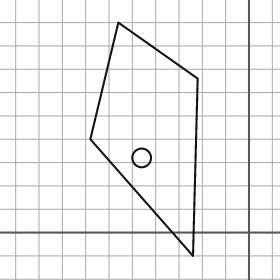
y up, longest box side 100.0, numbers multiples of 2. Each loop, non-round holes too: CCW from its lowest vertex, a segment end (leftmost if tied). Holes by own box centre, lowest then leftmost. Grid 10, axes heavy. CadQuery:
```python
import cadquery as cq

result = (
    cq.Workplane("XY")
    .moveTo(-24.0, -10.0)
    .lineTo(-22.0, 66.0)
    .lineTo(-56.0, 90.0)
    .lineTo(-68.0, 40.0)
    .close()
    .moveTo(-46.0, 32.0)
    .circle(4.0)
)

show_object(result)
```